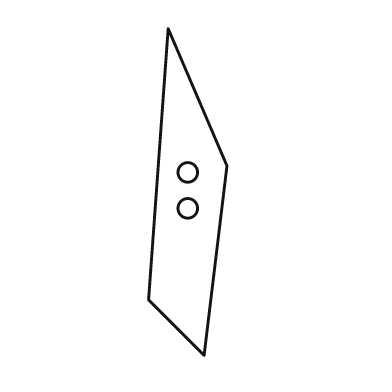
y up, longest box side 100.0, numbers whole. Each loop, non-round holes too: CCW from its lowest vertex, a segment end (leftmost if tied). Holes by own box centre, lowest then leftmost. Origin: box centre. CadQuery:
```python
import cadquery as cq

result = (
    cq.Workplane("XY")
    .moveTo(5.0, -50.0)
    .lineTo(12.0, 8.0)
    .lineTo(-6.0, 50.0)
    .lineTo(-12.0, -33.0)
    .close()
    .moveTo(0.0, -5.0)
    .circle(3.0)
    .moveTo(0.0, 6.0)
    .circle(3.0)
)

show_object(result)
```